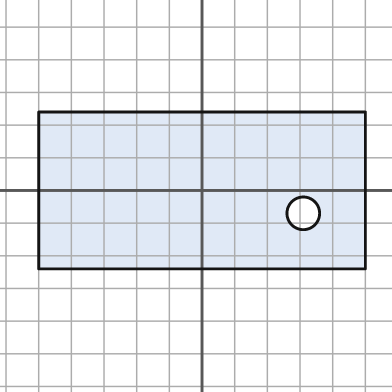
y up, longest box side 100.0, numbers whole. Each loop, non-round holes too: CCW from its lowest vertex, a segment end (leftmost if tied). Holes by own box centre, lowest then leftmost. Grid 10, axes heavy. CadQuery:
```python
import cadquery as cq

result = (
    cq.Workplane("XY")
    .moveTo(-50.0, -24.0)
    .lineTo(50.0, -24.0)
    .lineTo(50.0, 24.0)
    .lineTo(-50.0, 24.0)
    .close()
    .moveTo(31.0, -7.0)
    .circle(5.0)
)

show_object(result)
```